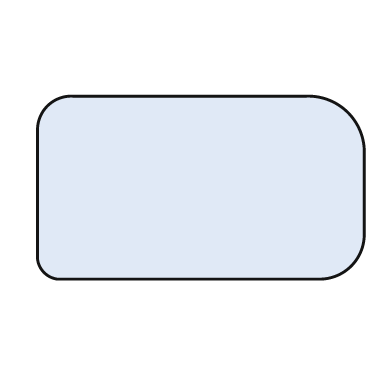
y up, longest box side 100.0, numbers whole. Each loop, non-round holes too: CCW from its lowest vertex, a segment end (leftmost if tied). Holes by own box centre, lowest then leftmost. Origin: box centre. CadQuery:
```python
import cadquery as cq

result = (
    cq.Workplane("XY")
    .moveTo(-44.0, -28.0)
    .lineTo(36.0, -28.0)
    .threePointArc((46.0, -24.0), (50.0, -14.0))
    .lineTo(50.0, 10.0)
    .threePointArc((45.0, 23.0), (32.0, 28.0))
    .lineTo(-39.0, 28.0)
    .threePointArc((-47.0, 25.0), (-50.0, 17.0))
    .lineTo(-50.0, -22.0)
    .threePointArc((-48.0, -26.0), (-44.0, -28.0))
    .close()
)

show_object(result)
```